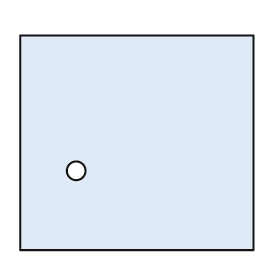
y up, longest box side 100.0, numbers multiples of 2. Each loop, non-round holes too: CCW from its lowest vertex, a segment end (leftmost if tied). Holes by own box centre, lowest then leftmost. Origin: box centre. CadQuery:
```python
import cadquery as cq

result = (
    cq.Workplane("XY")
    .moveTo(-50.0, -46.0)
    .lineTo(50.0, -46.0)
    .lineTo(50.0, 46.0)
    .lineTo(-50.0, 46.0)
    .close()
    .moveTo(-26.0, -12.0)
    .circle(4.0)
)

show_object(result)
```